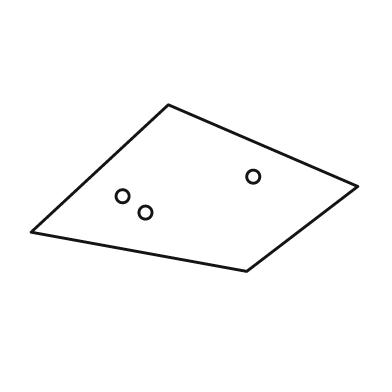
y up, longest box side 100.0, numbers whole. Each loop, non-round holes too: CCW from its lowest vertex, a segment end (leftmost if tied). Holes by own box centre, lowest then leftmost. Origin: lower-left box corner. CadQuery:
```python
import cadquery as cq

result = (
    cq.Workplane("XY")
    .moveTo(66.0, 0.0)
    .lineTo(100.0, 26.0)
    .lineTo(42.0, 51.0)
    .lineTo(0.0, 12.0)
    .close()
    .moveTo(35.0, 18.0)
    .circle(2.0)
    .moveTo(28.0, 23.0)
    .circle(2.0)
    .moveTo(68.0, 29.0)
    .circle(2.0)
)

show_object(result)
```